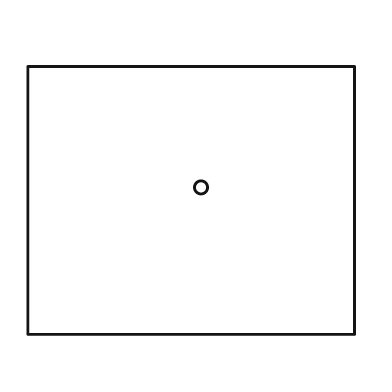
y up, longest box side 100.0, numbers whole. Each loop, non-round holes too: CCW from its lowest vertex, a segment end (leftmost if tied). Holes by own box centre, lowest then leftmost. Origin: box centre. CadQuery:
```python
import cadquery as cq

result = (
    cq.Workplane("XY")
    .moveTo(-50.0, -41.0)
    .lineTo(50.0, -41.0)
    .lineTo(50.0, 41.0)
    .lineTo(-50.0, 41.0)
    .close()
    .moveTo(3.0, 4.0)
    .circle(2.0)
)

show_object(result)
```